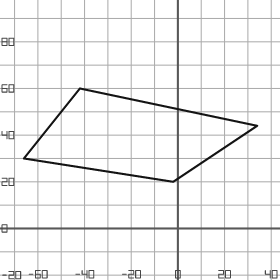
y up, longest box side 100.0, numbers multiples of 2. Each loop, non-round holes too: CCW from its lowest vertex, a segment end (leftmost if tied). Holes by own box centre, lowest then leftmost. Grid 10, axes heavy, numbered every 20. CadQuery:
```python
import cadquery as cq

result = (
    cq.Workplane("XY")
    .moveTo(-2.0, 20.0)
    .lineTo(34.0, 44.0)
    .lineTo(-42.0, 60.0)
    .lineTo(-66.0, 30.0)
    .close()
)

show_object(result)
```